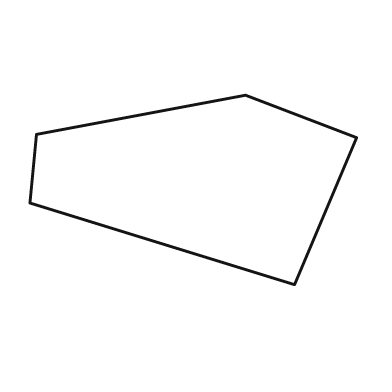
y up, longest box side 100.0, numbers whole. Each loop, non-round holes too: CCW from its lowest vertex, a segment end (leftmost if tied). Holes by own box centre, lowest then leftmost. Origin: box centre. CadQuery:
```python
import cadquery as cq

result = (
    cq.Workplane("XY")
    .moveTo(31.0, -29.0)
    .lineTo(50.0, 16.0)
    .lineTo(16.0, 29.0)
    .lineTo(-48.0, 17.0)
    .lineTo(-50.0, -4.0)
    .close()
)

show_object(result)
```